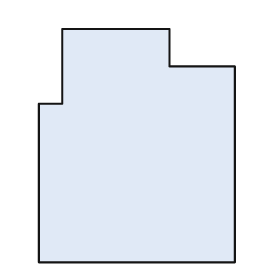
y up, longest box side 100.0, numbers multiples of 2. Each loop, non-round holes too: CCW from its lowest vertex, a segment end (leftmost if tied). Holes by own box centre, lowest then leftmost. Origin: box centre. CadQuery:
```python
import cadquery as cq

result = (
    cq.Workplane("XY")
    .moveTo(-42.0, -50.0)
    .lineTo(42.0, -50.0)
    .lineTo(42.0, 34.0)
    .lineTo(14.0, 34.0)
    .lineTo(14.0, 50.0)
    .lineTo(-32.0, 50.0)
    .lineTo(-32.0, 18.0)
    .lineTo(-42.0, 18.0)
    .close()
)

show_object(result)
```